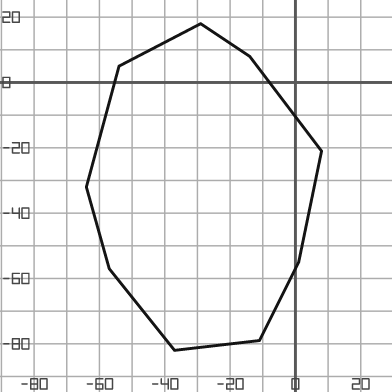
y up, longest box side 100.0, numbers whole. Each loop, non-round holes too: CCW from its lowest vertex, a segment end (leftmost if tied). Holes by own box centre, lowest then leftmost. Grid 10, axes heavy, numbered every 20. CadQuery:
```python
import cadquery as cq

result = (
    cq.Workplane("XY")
    .moveTo(-37.0, -82.0)
    .lineTo(-11.0, -79.0)
    .lineTo(1.0, -55.0)
    .lineTo(8.0, -21.0)
    .lineTo(-14.0, 8.0)
    .lineTo(-29.0, 18.0)
    .lineTo(-54.0, 5.0)
    .lineTo(-64.0, -32.0)
    .lineTo(-57.0, -57.0)
    .close()
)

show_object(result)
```